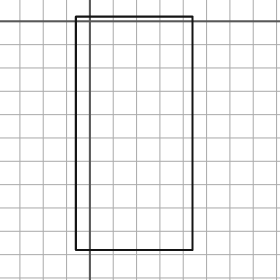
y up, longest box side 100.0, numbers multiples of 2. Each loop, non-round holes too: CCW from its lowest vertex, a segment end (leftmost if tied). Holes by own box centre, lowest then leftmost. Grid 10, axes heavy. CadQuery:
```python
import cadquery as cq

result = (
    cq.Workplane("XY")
    .moveTo(-6.0, -98.0)
    .lineTo(44.0, -98.0)
    .lineTo(44.0, 2.0)
    .lineTo(-6.0, 2.0)
    .close()
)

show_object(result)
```